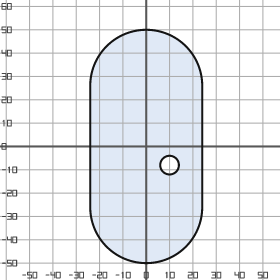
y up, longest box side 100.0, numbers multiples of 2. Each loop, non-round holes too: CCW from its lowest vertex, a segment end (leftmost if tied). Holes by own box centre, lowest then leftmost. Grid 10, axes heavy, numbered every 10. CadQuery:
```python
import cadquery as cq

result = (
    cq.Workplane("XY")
    .moveTo(-24.0, -26.0)
    .threePointArc((0.0, -50.0), (24.0, -26.0))
    .lineTo(24.0, 26.0)
    .threePointArc((0.0, 50.0), (-24.0, 26.0))
    .close()
    .moveTo(10.0, -8.0)
    .circle(4.0)
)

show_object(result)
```